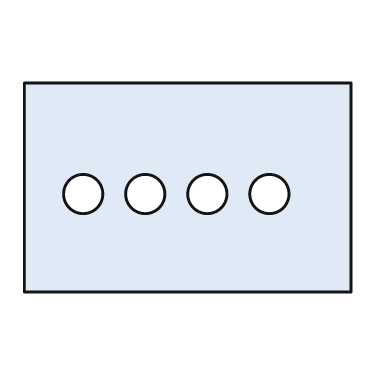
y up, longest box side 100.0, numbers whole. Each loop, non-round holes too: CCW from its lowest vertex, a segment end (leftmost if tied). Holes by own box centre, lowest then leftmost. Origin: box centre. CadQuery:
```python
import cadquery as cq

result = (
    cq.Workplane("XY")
    .moveTo(-50.0, -32.0)
    .lineTo(50.0, -32.0)
    .lineTo(50.0, 32.0)
    .lineTo(-50.0, 32.0)
    .close()
    .moveTo(-32.0, -2.0)
    .circle(6.0)
    .moveTo(-13.0, -2.0)
    .circle(6.0)
    .moveTo(6.0, -2.0)
    .circle(6.0)
    .moveTo(25.0, -2.0)
    .circle(6.0)
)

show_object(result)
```